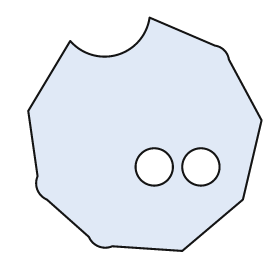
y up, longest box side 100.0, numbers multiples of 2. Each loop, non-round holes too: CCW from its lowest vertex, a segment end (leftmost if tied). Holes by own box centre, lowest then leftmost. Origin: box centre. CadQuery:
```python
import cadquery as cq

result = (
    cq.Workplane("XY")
    .moveTo(16.0, -50.0)
    .lineTo(42.0, -28.0)
    .lineTo(50.0, 6.0)
    .lineTo(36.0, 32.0)
    .threePointArc((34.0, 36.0), (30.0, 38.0))
    .lineTo(2.0, 50.0)
    .threePointArc((-12.0, 34.0), (-32.0, 40.0))
    .lineTo(-50.0, 10.0)
    .lineTo(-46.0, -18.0)
    .threePointArc((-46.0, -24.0), (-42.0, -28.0))
    .lineTo(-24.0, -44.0)
    .threePointArc((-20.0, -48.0), (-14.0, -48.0))
    .close()
    .moveTo(4.0, -14.0)
    .circle(8.0)
    .moveTo(24.0, -14.0)
    .circle(8.0)
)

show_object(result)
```